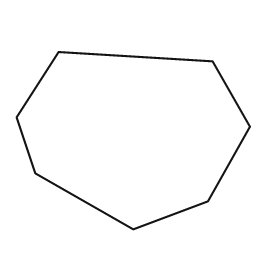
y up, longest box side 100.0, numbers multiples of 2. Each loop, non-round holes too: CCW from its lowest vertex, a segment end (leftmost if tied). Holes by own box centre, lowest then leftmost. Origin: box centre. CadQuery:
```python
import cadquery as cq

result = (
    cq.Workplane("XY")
    .moveTo(0.0, -38.0)
    .lineTo(32.0, -26.0)
    .lineTo(50.0, 6.0)
    .lineTo(34.0, 34.0)
    .lineTo(-32.0, 38.0)
    .lineTo(-50.0, 10.0)
    .lineTo(-42.0, -14.0)
    .close()
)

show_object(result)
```